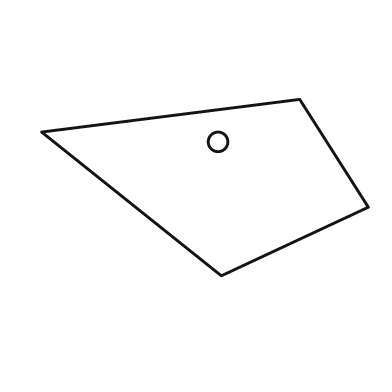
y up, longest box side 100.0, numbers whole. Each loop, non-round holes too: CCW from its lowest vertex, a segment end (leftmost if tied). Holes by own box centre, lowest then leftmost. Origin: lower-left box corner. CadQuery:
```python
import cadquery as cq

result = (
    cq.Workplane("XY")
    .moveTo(55.0, 0.0)
    .lineTo(100.0, 21.0)
    .lineTo(79.0, 54.0)
    .lineTo(0.0, 44.0)
    .close()
    .moveTo(54.0, 41.0)
    .circle(3.0)
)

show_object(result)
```